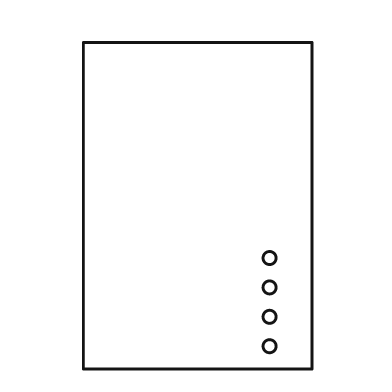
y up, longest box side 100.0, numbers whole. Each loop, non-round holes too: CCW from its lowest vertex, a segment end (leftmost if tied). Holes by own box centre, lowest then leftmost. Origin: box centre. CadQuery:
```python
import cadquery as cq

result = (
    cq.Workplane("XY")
    .moveTo(-35.0, -50.0)
    .lineTo(35.0, -50.0)
    .lineTo(35.0, 50.0)
    .lineTo(-35.0, 50.0)
    .close()
    .moveTo(22.0, -43.0)
    .circle(2.0)
    .moveTo(22.0, -34.0)
    .circle(2.0)
    .moveTo(22.0, -25.0)
    .circle(2.0)
    .moveTo(22.0, -16.0)
    .circle(2.0)
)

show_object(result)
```